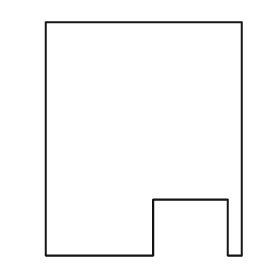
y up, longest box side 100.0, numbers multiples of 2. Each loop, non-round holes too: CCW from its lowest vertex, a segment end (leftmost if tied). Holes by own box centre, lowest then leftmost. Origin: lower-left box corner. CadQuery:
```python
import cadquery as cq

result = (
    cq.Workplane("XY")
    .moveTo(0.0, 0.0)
    .lineTo(46.0, 0.0)
    .lineTo(46.0, 24.0)
    .lineTo(78.0, 24.0)
    .lineTo(78.0, 0.0)
    .lineTo(84.0, 0.0)
    .lineTo(84.0, 100.0)
    .lineTo(0.0, 100.0)
    .close()
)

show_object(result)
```